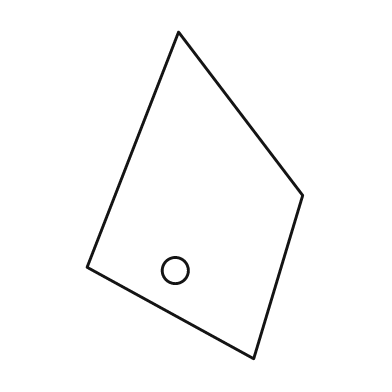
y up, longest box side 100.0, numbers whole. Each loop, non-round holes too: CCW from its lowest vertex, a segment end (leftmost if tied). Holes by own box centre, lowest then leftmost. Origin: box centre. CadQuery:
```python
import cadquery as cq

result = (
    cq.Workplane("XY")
    .moveTo(18.0, -50.0)
    .lineTo(33.0, 0.0)
    .lineTo(-5.0, 50.0)
    .lineTo(-33.0, -22.0)
    .close()
    .moveTo(-6.0, -23.0)
    .circle(4.0)
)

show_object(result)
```